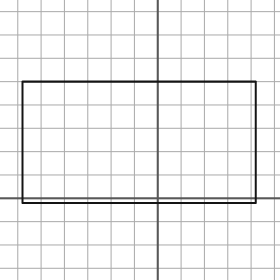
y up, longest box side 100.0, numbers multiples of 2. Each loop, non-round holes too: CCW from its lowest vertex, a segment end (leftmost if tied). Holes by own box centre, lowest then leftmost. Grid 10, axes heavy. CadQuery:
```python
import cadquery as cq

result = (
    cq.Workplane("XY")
    .moveTo(-58.0, -2.0)
    .lineTo(42.0, -2.0)
    .lineTo(42.0, 50.0)
    .lineTo(-58.0, 50.0)
    .close()
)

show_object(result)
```